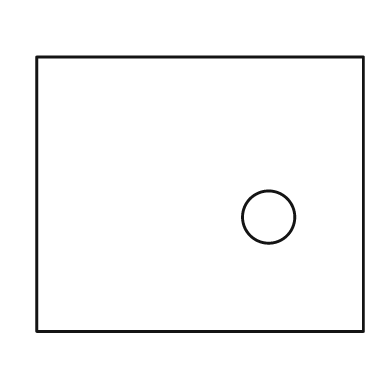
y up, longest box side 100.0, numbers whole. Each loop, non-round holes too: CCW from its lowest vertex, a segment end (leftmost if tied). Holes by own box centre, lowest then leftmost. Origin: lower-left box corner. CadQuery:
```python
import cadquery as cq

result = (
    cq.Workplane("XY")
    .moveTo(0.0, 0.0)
    .lineTo(100.0, 0.0)
    .lineTo(100.0, 84.0)
    .lineTo(0.0, 84.0)
    .close()
    .moveTo(71.0, 35.0)
    .circle(8.0)
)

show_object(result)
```